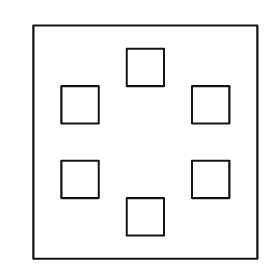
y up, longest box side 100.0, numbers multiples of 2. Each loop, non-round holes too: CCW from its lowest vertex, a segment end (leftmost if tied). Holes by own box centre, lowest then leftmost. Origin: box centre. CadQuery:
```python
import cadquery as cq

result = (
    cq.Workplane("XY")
    .moveTo(-48.0, -50.0)
    .lineTo(48.0, -50.0)
    .lineTo(48.0, 50.0)
    .lineTo(-48.0, 50.0)
    .close()
    .moveTo(-8.0, -40.0)
    .lineTo(8.0, -40.0)
    .lineTo(8.0, -24.0)
    .lineTo(-8.0, -24.0)
    .close()
    .moveTo(-36.0, -24.0)
    .lineTo(-20.0, -24.0)
    .lineTo(-20.0, -8.0)
    .lineTo(-36.0, -8.0)
    .close()
    .moveTo(20.0, -24.0)
    .lineTo(36.0, -24.0)
    .lineTo(36.0, -8.0)
    .lineTo(20.0, -8.0)
    .close()
    .moveTo(-36.0, 8.0)
    .lineTo(-20.0, 8.0)
    .lineTo(-20.0, 24.0)
    .lineTo(-36.0, 24.0)
    .close()
    .moveTo(20.0, 8.0)
    .lineTo(36.0, 8.0)
    .lineTo(36.0, 24.0)
    .lineTo(20.0, 24.0)
    .close()
    .moveTo(-8.0, 24.0)
    .lineTo(8.0, 24.0)
    .lineTo(8.0, 40.0)
    .lineTo(-8.0, 40.0)
    .close()
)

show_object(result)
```